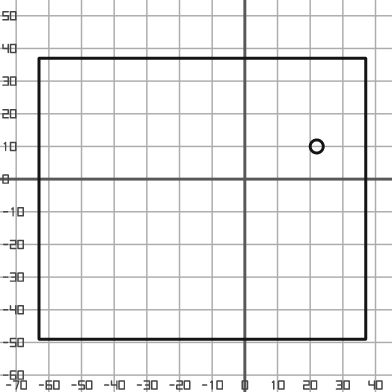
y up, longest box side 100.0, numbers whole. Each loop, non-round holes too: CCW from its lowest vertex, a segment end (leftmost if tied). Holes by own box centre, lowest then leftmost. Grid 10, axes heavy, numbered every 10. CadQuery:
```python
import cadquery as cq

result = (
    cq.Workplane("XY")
    .moveTo(-63.0, -49.0)
    .lineTo(37.0, -49.0)
    .lineTo(37.0, 37.0)
    .lineTo(-63.0, 37.0)
    .close()
    .moveTo(22.0, 10.0)
    .circle(2.0)
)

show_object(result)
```